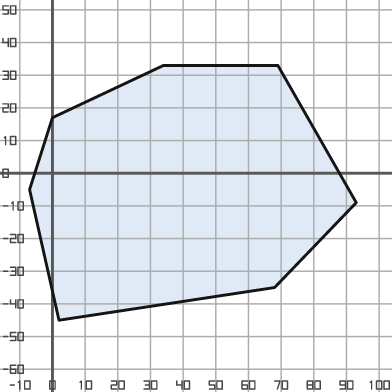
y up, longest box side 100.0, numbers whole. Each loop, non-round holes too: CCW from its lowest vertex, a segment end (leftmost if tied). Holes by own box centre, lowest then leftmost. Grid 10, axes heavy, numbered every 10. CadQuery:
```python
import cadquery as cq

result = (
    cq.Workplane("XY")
    .moveTo(2.0, -45.0)
    .lineTo(68.0, -35.0)
    .lineTo(93.0, -9.0)
    .lineTo(69.0, 33.0)
    .lineTo(34.0, 33.0)
    .lineTo(0.0, 17.0)
    .lineTo(-7.0, -5.0)
    .close()
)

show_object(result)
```